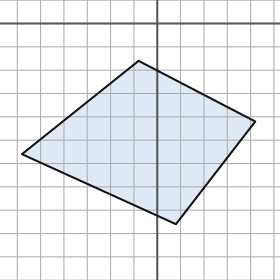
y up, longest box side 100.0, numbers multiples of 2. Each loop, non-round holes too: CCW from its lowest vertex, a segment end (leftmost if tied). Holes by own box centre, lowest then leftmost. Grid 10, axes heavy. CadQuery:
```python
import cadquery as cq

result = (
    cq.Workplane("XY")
    .moveTo(8.0, -86.0)
    .lineTo(42.0, -42.0)
    .lineTo(-8.0, -16.0)
    .lineTo(-58.0, -56.0)
    .close()
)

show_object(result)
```